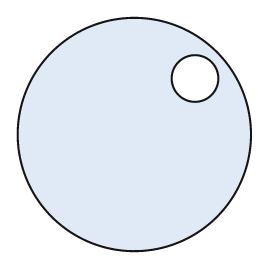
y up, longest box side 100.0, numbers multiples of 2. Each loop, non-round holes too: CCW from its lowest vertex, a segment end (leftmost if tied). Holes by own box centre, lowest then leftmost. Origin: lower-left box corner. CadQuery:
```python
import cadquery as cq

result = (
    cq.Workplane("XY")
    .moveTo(50.0, 50.0)
    .circle(50.0)
    .moveTo(76.0, 74.0)
    .circle(10.0)
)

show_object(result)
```